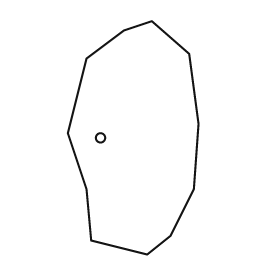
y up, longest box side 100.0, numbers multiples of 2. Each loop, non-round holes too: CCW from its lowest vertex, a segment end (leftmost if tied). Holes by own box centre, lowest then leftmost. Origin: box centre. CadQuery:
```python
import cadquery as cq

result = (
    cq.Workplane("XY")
    .moveTo(6.0, -50.0)
    .lineTo(16.0, -42.0)
    .lineTo(26.0, -22.0)
    .lineTo(28.0, 6.0)
    .lineTo(24.0, 36.0)
    .lineTo(8.0, 50.0)
    .lineTo(-4.0, 46.0)
    .lineTo(-20.0, 34.0)
    .lineTo(-28.0, 2.0)
    .lineTo(-20.0, -22.0)
    .lineTo(-18.0, -44.0)
    .close()
    .moveTo(-14.0, 0.0)
    .circle(2.0)
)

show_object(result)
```